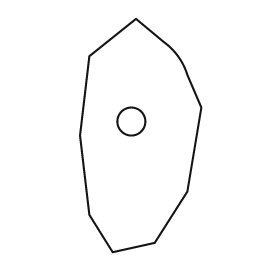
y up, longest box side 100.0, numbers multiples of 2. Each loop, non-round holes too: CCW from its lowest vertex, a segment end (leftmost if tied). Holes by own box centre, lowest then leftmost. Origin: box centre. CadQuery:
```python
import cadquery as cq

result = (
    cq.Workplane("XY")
    .moveTo(-12.0, -50.0)
    .lineTo(6.0, -46.0)
    .lineTo(20.0, -24.0)
    .lineTo(26.0, 12.0)
    .lineTo(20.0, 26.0)
    .threePointArc((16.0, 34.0), (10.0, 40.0))
    .lineTo(-2.0, 50.0)
    .lineTo(-22.0, 34.0)
    .lineTo(-26.0, 0.0)
    .lineTo(-22.0, -34.0)
    .close()
    .moveTo(-4.0, 6.0)
    .circle(6.0)
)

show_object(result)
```